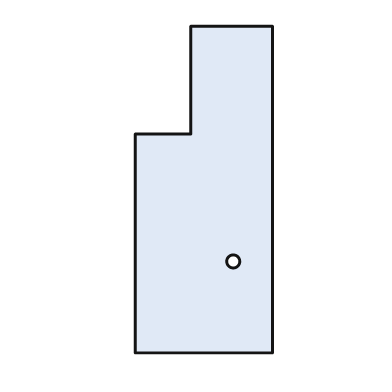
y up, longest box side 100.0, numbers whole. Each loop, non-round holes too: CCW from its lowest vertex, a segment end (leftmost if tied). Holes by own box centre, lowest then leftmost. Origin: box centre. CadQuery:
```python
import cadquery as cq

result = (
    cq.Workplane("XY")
    .moveTo(-21.0, -50.0)
    .lineTo(21.0, -50.0)
    .lineTo(21.0, 50.0)
    .lineTo(-4.0, 50.0)
    .lineTo(-4.0, 17.0)
    .lineTo(-21.0, 17.0)
    .close()
    .moveTo(9.0, -22.0)
    .circle(2.0)
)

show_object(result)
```